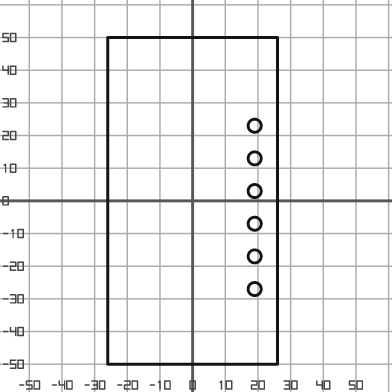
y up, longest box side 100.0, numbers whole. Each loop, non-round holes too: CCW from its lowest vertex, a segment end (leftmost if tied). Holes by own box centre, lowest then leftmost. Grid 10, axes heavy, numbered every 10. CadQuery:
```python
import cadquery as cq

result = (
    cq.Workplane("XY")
    .moveTo(-26.0, -50.0)
    .lineTo(26.0, -50.0)
    .lineTo(26.0, 50.0)
    .lineTo(-26.0, 50.0)
    .close()
    .moveTo(19.0, -27.0)
    .circle(2.0)
    .moveTo(19.0, -17.0)
    .circle(2.0)
    .moveTo(19.0, -7.0)
    .circle(2.0)
    .moveTo(19.0, 3.0)
    .circle(2.0)
    .moveTo(19.0, 13.0)
    .circle(2.0)
    .moveTo(19.0, 23.0)
    .circle(2.0)
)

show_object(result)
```